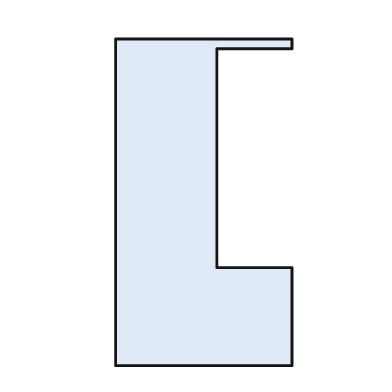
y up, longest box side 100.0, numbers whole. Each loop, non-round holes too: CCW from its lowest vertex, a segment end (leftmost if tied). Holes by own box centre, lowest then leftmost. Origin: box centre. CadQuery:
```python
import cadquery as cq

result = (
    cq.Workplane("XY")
    .moveTo(-27.0, -50.0)
    .lineTo(27.0, -50.0)
    .lineTo(27.0, -20.0)
    .lineTo(4.0, -20.0)
    .lineTo(4.0, 47.0)
    .lineTo(27.0, 47.0)
    .lineTo(27.0, 50.0)
    .lineTo(-27.0, 50.0)
    .close()
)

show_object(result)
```